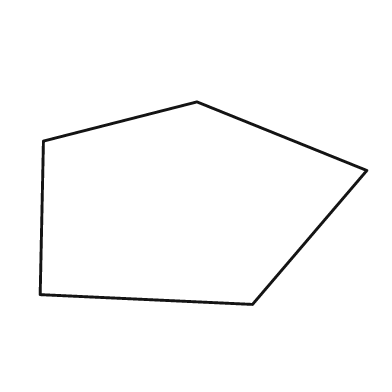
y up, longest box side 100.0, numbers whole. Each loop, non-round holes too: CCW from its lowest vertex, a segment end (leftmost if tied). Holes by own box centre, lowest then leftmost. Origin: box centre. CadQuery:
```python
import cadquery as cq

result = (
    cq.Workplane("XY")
    .moveTo(15.0, -31.0)
    .lineTo(50.0, 10.0)
    .lineTo(-2.0, 31.0)
    .lineTo(-49.0, 19.0)
    .lineTo(-50.0, -28.0)
    .close()
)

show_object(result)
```